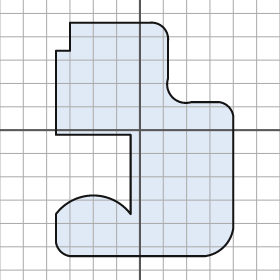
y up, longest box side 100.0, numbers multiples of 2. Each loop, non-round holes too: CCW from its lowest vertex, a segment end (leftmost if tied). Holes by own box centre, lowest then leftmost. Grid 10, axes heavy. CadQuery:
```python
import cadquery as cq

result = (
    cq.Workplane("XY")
    .moveTo(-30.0, -54.0)
    .lineTo(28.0, -54.0)
    .threePointArc((36.0, -50.0), (40.0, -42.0))
    .lineTo(40.0, 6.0)
    .threePointArc((38.0, 10.0), (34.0, 12.0))
    .lineTo(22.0, 12.0)
    .threePointArc((14.0, 14.0), (12.0, 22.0))
    .lineTo(12.0, 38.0)
    .threePointArc((10.0, 44.0), (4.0, 46.0))
    .lineTo(-30.0, 46.0)
    .lineTo(-30.0, 34.0)
    .lineTo(-36.0, 34.0)
    .lineTo(-36.0, -2.0)
    .lineTo(-4.0, -2.0)
    .lineTo(-4.0, -36.0)
    .threePointArc((-20.0, -28.0), (-36.0, -36.0))
    .lineTo(-36.0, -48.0)
    .threePointArc((-34.0, -52.0), (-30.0, -54.0))
    .close()
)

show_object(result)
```